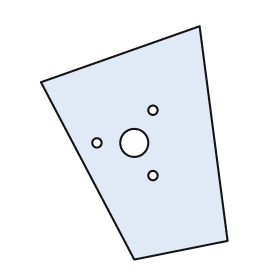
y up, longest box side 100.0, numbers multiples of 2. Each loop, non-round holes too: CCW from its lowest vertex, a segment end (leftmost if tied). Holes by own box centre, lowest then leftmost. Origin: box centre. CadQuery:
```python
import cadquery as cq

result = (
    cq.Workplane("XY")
    .moveTo(0.0, -50.0)
    .lineTo(40.0, -42.0)
    .lineTo(28.0, 50.0)
    .lineTo(-40.0, 26.0)
    .close()
    .moveTo(8.0, -14.0)
    .circle(2.0)
    .moveTo(-16.0, 0.0)
    .circle(2.0)
    .moveTo(0.0, 0.0)
    .circle(6.0)
    .moveTo(8.0, 14.0)
    .circle(2.0)
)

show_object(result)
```